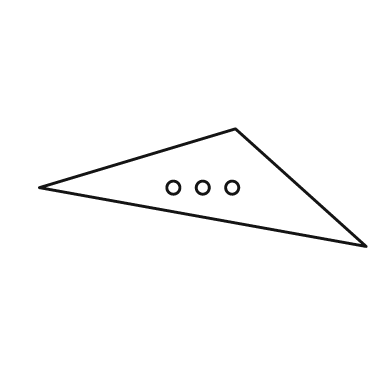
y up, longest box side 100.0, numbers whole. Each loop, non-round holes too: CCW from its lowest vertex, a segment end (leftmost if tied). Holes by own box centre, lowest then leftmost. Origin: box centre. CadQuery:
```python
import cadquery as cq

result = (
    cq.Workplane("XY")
    .moveTo(50.0, -18.0)
    .lineTo(10.0, 18.0)
    .lineTo(-50.0, 0.0)
    .close()
    .moveTo(-9.0, 0.0)
    .circle(2.0)
    .moveTo(0.0, 0.0)
    .circle(2.0)
    .moveTo(9.0, 0.0)
    .circle(2.0)
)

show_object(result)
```